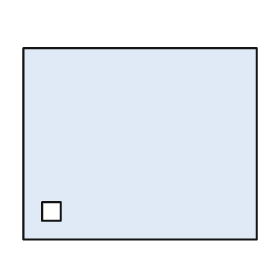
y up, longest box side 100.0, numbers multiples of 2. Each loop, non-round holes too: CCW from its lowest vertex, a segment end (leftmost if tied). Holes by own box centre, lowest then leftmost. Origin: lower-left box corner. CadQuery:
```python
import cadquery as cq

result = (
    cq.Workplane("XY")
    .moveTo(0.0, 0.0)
    .lineTo(100.0, 0.0)
    .lineTo(100.0, 82.0)
    .lineTo(0.0, 82.0)
    .close()
    .moveTo(8.0, 8.0)
    .lineTo(16.0, 8.0)
    .lineTo(16.0, 16.0)
    .lineTo(8.0, 16.0)
    .close()
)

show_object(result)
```